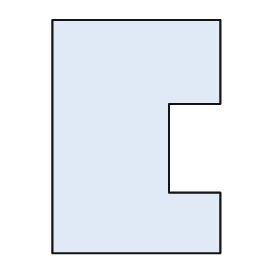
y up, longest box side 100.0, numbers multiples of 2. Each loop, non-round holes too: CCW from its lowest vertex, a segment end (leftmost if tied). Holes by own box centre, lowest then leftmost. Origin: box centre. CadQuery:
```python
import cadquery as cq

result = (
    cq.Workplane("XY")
    .moveTo(-36.0, -50.0)
    .lineTo(36.0, -50.0)
    .lineTo(36.0, -24.0)
    .lineTo(14.0, -24.0)
    .lineTo(14.0, 14.0)
    .lineTo(36.0, 14.0)
    .lineTo(36.0, 50.0)
    .lineTo(-36.0, 50.0)
    .close()
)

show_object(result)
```